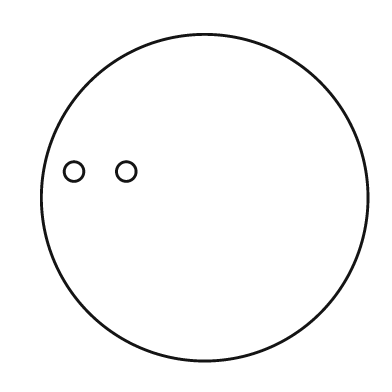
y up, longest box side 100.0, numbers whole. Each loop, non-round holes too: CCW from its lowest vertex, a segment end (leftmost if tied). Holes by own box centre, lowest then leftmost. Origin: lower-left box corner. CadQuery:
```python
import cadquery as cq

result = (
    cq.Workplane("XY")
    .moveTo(50.0, 50.0)
    .circle(50.0)
    .moveTo(10.0, 58.0)
    .circle(3.0)
    .moveTo(26.0, 58.0)
    .circle(3.0)
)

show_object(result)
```